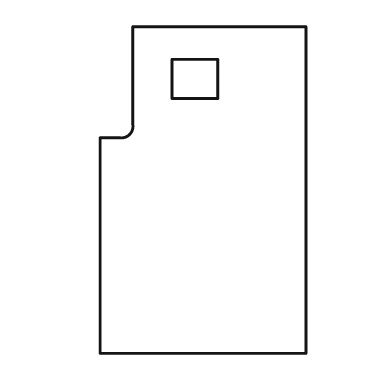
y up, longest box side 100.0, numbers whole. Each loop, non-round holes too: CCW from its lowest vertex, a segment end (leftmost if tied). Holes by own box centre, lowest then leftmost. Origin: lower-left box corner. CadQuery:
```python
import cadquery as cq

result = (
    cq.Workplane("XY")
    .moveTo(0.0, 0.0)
    .lineTo(63.0, 0.0)
    .lineTo(63.0, 100.0)
    .lineTo(10.0, 100.0)
    .lineTo(10.0, 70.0)
    .threePointArc((9.0, 67.0), (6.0, 66.0))
    .lineTo(0.0, 66.0)
    .close()
    .moveTo(22.0, 78.0)
    .lineTo(36.0, 78.0)
    .lineTo(36.0, 90.0)
    .lineTo(22.0, 90.0)
    .close()
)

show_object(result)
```